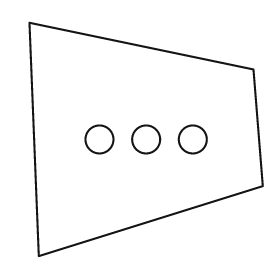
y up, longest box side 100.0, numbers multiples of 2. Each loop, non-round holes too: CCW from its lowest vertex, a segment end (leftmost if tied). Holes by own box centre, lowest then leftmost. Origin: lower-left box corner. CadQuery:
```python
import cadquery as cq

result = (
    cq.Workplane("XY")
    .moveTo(4.0, 0.0)
    .lineTo(100.0, 30.0)
    .lineTo(96.0, 80.0)
    .lineTo(0.0, 100.0)
    .close()
    .moveTo(30.0, 50.0)
    .circle(6.0)
    .moveTo(50.0, 50.0)
    .circle(6.0)
    .moveTo(70.0, 50.0)
    .circle(6.0)
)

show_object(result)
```